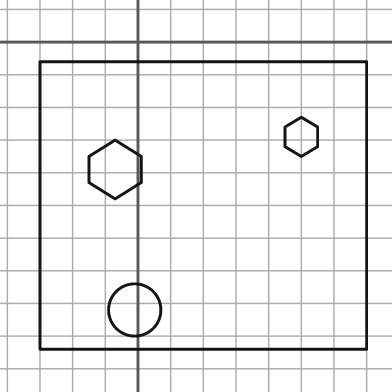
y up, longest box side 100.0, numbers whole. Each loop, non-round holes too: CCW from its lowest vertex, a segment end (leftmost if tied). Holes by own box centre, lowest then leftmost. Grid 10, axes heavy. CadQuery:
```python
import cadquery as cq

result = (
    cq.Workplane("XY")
    .moveTo(-30.0, -94.0)
    .lineTo(70.0, -94.0)
    .lineTo(70.0, -6.0)
    .lineTo(-30.0, -6.0)
    .close()
    .moveTo(-1.0, -82.0)
    .circle(8.0)
    .moveTo(-7.0, -48.0)
    .lineTo(1.0, -43.0)
    .lineTo(1.0, -35.0)
    .lineTo(-7.0, -30.0)
    .lineTo(-15.0, -35.0)
    .lineTo(-15.0, -43.0)
    .close()
    .moveTo(50.0, -35.0)
    .lineTo(55.0, -32.0)
    .lineTo(55.0, -26.0)
    .lineTo(50.0, -23.0)
    .lineTo(45.0, -26.0)
    .lineTo(45.0, -32.0)
    .close()
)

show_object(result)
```